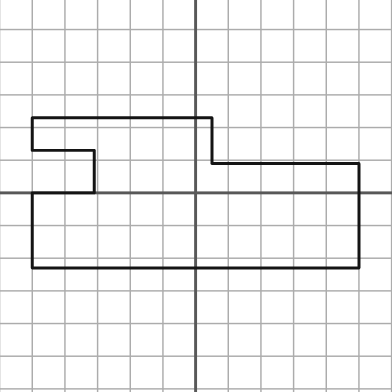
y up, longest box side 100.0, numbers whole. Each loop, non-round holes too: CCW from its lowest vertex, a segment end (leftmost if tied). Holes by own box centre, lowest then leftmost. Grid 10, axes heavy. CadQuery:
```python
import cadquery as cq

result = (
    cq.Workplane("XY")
    .moveTo(-50.0, -23.0)
    .lineTo(50.0, -23.0)
    .lineTo(50.0, 9.0)
    .lineTo(5.0, 9.0)
    .lineTo(5.0, 23.0)
    .lineTo(-50.0, 23.0)
    .lineTo(-50.0, 13.0)
    .lineTo(-31.0, 13.0)
    .lineTo(-31.0, 0.0)
    .lineTo(-50.0, 0.0)
    .close()
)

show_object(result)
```